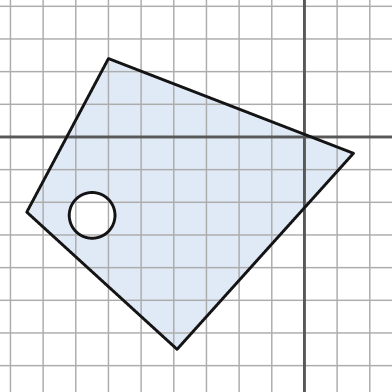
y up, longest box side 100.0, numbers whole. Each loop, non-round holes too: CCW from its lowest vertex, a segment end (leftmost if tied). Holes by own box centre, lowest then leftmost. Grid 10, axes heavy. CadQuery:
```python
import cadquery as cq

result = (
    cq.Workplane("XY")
    .moveTo(-39.0, -65.0)
    .lineTo(15.0, -5.0)
    .lineTo(-60.0, 24.0)
    .lineTo(-85.0, -23.0)
    .close()
    .moveTo(-65.0, -24.0)
    .circle(7.0)
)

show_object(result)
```